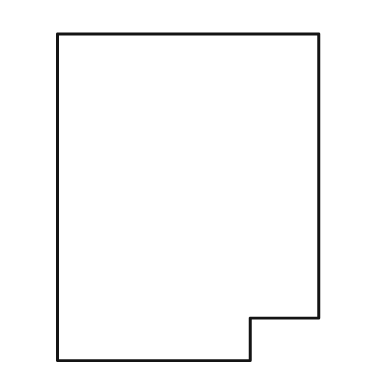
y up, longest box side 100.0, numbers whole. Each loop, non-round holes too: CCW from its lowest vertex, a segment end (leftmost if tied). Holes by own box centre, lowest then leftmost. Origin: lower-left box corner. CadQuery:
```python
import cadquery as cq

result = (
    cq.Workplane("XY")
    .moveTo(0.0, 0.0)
    .lineTo(59.0, 0.0)
    .lineTo(59.0, 13.0)
    .lineTo(80.0, 13.0)
    .lineTo(80.0, 100.0)
    .lineTo(0.0, 100.0)
    .close()
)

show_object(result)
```